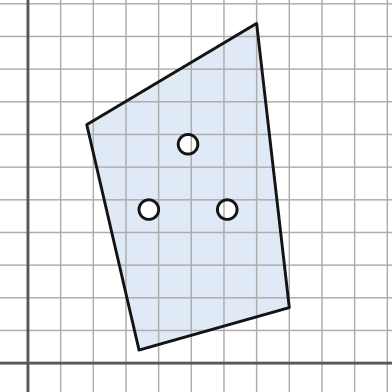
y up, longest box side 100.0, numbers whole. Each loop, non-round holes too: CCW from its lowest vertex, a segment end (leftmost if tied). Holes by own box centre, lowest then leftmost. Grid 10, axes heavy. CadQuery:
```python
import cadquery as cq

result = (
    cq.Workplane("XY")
    .moveTo(34.0, 4.0)
    .lineTo(80.0, 17.0)
    .lineTo(70.0, 104.0)
    .lineTo(18.0, 73.0)
    .close()
    .moveTo(37.0, 47.0)
    .circle(3.0)
    .moveTo(61.0, 47.0)
    .circle(3.0)
    .moveTo(49.0, 67.0)
    .circle(3.0)
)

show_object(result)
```